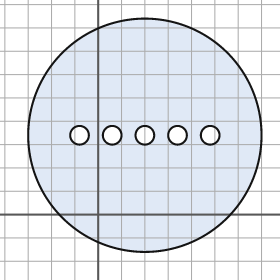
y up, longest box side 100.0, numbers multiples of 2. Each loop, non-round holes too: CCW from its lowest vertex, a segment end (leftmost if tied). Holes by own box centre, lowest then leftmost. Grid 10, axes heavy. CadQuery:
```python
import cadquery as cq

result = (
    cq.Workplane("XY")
    .moveTo(20.0, 34.0)
    .circle(50.0)
    .moveTo(-8.0, 34.0)
    .circle(4.0)
    .moveTo(6.0, 34.0)
    .circle(4.0)
    .moveTo(20.0, 34.0)
    .circle(4.0)
    .moveTo(34.0, 34.0)
    .circle(4.0)
    .moveTo(48.0, 34.0)
    .circle(4.0)
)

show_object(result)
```